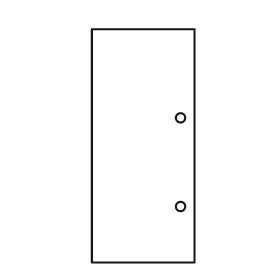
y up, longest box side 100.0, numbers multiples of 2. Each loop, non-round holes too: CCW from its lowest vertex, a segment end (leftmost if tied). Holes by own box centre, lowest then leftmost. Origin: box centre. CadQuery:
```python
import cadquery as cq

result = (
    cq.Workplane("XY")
    .moveTo(-22.0, -50.0)
    .lineTo(22.0, -50.0)
    .lineTo(22.0, 50.0)
    .lineTo(-22.0, 50.0)
    .close()
    .moveTo(16.0, -26.0)
    .circle(2.0)
    .moveTo(16.0, 12.0)
    .circle(2.0)
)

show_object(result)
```